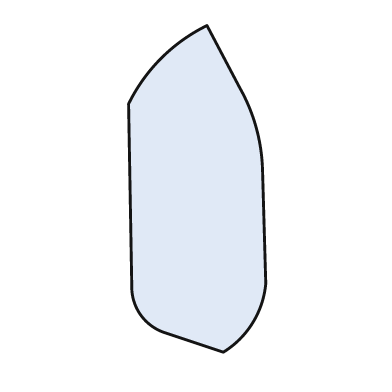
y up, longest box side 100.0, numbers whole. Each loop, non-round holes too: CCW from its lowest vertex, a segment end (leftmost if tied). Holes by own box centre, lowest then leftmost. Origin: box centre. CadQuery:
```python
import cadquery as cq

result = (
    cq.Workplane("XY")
    .moveTo(8.0, -50.0)
    .threePointArc((17.0, -41.0), (21.0, -29.0))
    .lineTo(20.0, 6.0)
    .threePointArc((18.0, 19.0), (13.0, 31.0))
    .lineTo(3.0, 50.0)
    .threePointArc((-11.0, 40.0), (-21.0, 26.0))
    .lineTo(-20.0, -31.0)
    .threePointArc((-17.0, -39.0), (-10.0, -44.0))
    .close()
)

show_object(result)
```